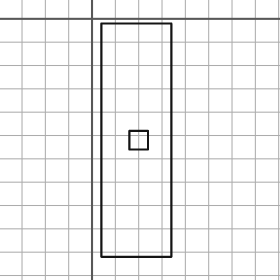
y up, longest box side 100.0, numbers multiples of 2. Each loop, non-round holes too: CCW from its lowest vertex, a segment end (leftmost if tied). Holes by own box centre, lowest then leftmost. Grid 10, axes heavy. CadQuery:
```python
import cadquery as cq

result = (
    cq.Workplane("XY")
    .moveTo(4.0, -102.0)
    .lineTo(34.0, -102.0)
    .lineTo(34.0, -2.0)
    .lineTo(4.0, -2.0)
    .close()
    .moveTo(16.0, -56.0)
    .lineTo(24.0, -56.0)
    .lineTo(24.0, -48.0)
    .lineTo(16.0, -48.0)
    .close()
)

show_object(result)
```